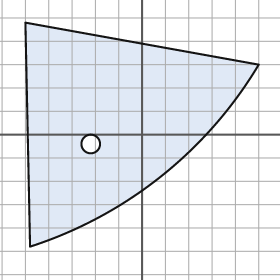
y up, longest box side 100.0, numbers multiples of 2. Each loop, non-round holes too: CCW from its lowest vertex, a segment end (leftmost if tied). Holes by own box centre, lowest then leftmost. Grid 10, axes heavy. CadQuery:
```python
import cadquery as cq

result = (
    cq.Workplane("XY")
    .moveTo(-48.0, -48.0)
    .threePointArc((8.0, -18.0), (50.0, 30.0))
    .lineTo(-50.0, 48.0)
    .close()
    .moveTo(-22.0, -4.0)
    .circle(4.0)
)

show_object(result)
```